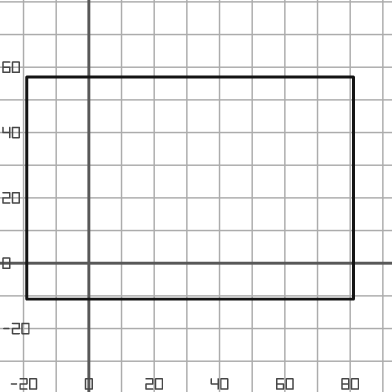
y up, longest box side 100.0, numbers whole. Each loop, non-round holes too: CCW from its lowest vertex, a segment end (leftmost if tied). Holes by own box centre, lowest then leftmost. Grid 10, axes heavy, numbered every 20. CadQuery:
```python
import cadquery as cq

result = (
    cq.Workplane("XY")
    .moveTo(-19.0, -11.0)
    .lineTo(81.0, -11.0)
    .lineTo(81.0, 57.0)
    .lineTo(-19.0, 57.0)
    .close()
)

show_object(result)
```